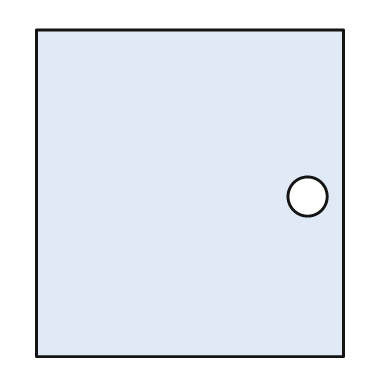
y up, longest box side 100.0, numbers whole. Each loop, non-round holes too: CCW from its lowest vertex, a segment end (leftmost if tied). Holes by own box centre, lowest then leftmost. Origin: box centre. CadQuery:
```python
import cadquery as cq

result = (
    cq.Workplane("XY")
    .moveTo(-47.0, -50.0)
    .lineTo(47.0, -50.0)
    .lineTo(47.0, 50.0)
    .lineTo(-47.0, 50.0)
    .close()
    .moveTo(36.0, -1.0)
    .circle(6.0)
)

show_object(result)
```